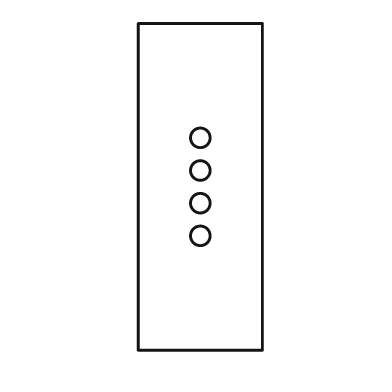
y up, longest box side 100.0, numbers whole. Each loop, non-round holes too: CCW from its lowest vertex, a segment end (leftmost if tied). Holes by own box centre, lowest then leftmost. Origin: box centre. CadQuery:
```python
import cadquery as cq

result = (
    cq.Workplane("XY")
    .moveTo(-19.0, -50.0)
    .lineTo(19.0, -50.0)
    .lineTo(19.0, 50.0)
    .lineTo(-19.0, 50.0)
    .close()
    .moveTo(0.0, -15.0)
    .circle(3.0)
    .moveTo(0.0, -5.0)
    .circle(3.0)
    .moveTo(0.0, 5.0)
    .circle(3.0)
    .moveTo(0.0, 15.0)
    .circle(3.0)
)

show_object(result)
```